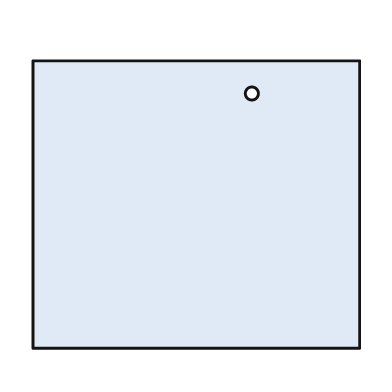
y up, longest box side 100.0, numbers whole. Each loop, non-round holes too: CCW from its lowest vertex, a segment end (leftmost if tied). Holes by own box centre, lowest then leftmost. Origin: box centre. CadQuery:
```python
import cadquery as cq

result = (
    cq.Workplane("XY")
    .moveTo(-50.0, -44.0)
    .lineTo(50.0, -44.0)
    .lineTo(50.0, 44.0)
    .lineTo(-50.0, 44.0)
    .close()
    .moveTo(17.0, 34.0)
    .circle(2.0)
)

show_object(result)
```